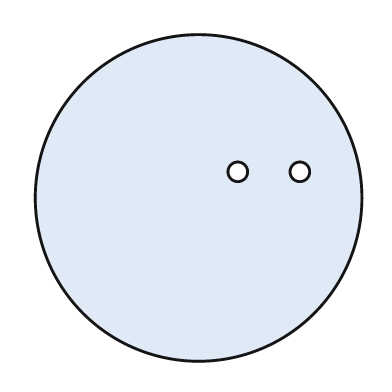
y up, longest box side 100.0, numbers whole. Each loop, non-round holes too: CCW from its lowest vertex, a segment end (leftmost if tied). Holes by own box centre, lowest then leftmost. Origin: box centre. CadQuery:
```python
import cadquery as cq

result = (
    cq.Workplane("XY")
    .moveTo(0.0, 0.0)
    .circle(50.0)
    .moveTo(12.0, 8.0)
    .circle(3.0)
    .moveTo(31.0, 8.0)
    .circle(3.0)
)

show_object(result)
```